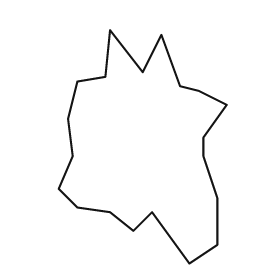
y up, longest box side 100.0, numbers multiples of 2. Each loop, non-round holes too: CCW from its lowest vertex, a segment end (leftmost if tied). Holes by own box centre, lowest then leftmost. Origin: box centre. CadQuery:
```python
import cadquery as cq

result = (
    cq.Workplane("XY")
    .moveTo(20.0, -50.0)
    .lineTo(32.0, -42.0)
    .lineTo(32.0, -22.0)
    .lineTo(26.0, -4.0)
    .lineTo(26.0, 4.0)
    .lineTo(36.0, 18.0)
    .lineTo(24.0, 24.0)
    .lineTo(16.0, 26.0)
    .lineTo(8.0, 48.0)
    .lineTo(0.0, 32.0)
    .lineTo(-14.0, 50.0)
    .lineTo(-16.0, 30.0)
    .lineTo(-28.0, 28.0)
    .lineTo(-32.0, 12.0)
    .lineTo(-30.0, -4.0)
    .lineTo(-36.0, -18.0)
    .lineTo(-28.0, -26.0)
    .lineTo(-14.0, -28.0)
    .lineTo(-4.0, -36.0)
    .lineTo(4.0, -28.0)
    .close()
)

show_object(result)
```